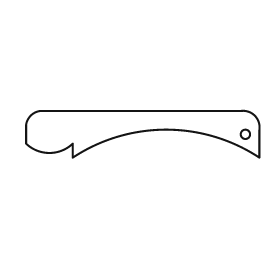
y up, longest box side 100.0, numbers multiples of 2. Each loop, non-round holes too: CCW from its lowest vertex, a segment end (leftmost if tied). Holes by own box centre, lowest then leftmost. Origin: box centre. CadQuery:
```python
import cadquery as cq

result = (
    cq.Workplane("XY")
    .moveTo(-30.0, -10.0)
    .threePointArc((10.0, 2.0), (50.0, -10.0))
    .lineTo(50.0, 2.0)
    .threePointArc((48.0, 8.0), (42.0, 10.0))
    .lineTo(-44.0, 10.0)
    .threePointArc((-48.0, 8.0), (-50.0, 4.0))
    .lineTo(-50.0, -4.0)
    .threePointArc((-40.0, -8.0), (-30.0, -4.0))
    .close()
    .moveTo(44.0, 0.0)
    .circle(2.0)
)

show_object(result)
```